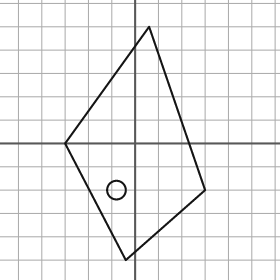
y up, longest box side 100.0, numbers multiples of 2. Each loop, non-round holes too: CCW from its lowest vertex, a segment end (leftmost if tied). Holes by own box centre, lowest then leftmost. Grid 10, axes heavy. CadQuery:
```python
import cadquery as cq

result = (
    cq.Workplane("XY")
    .moveTo(-4.0, -50.0)
    .lineTo(30.0, -20.0)
    .lineTo(6.0, 50.0)
    .lineTo(-30.0, 0.0)
    .close()
    .moveTo(-8.0, -20.0)
    .circle(4.0)
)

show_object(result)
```